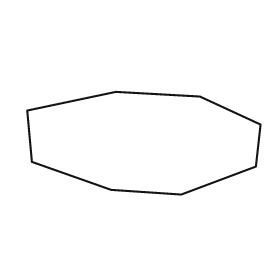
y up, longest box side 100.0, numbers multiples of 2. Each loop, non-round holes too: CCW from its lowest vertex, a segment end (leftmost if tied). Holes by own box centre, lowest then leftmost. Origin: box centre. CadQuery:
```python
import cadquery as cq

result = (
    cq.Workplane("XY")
    .moveTo(16.0, -22.0)
    .lineTo(48.0, -10.0)
    .lineTo(50.0, 8.0)
    .lineTo(24.0, 20.0)
    .lineTo(-12.0, 22.0)
    .lineTo(-50.0, 14.0)
    .lineTo(-48.0, -8.0)
    .lineTo(-14.0, -20.0)
    .close()
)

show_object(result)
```